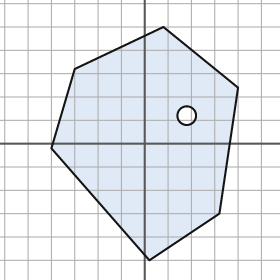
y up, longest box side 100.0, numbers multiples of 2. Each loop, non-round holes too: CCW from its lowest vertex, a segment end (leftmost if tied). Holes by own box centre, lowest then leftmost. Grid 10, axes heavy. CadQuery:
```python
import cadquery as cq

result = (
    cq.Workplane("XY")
    .moveTo(2.0, -50.0)
    .lineTo(32.0, -30.0)
    .lineTo(40.0, 24.0)
    .lineTo(8.0, 50.0)
    .lineTo(-30.0, 32.0)
    .lineTo(-40.0, -2.0)
    .close()
    .moveTo(18.0, 12.0)
    .circle(4.0)
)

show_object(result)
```